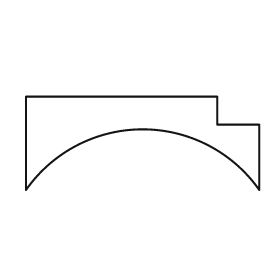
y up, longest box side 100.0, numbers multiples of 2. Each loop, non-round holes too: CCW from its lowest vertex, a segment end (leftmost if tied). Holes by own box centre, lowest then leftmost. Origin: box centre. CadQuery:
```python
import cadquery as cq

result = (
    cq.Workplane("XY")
    .moveTo(-50.0, -20.0)
    .threePointArc((0.0, 6.0), (50.0, -20.0))
    .lineTo(50.0, 8.0)
    .lineTo(32.0, 8.0)
    .lineTo(32.0, 20.0)
    .lineTo(-50.0, 20.0)
    .close()
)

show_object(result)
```